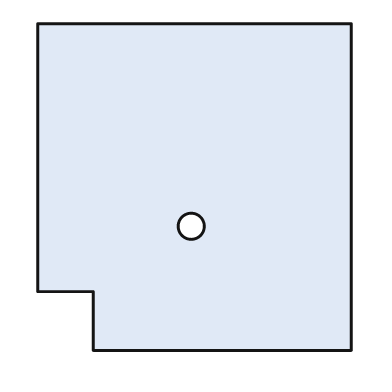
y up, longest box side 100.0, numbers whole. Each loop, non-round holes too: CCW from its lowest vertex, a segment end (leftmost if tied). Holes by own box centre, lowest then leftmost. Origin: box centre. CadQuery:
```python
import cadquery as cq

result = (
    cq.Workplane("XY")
    .moveTo(-31.0, -50.0)
    .lineTo(48.0, -50.0)
    .lineTo(48.0, 50.0)
    .lineTo(-48.0, 50.0)
    .lineTo(-48.0, -32.0)
    .lineTo(-31.0, -32.0)
    .close()
    .moveTo(-1.0, -12.0)
    .circle(4.0)
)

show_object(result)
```